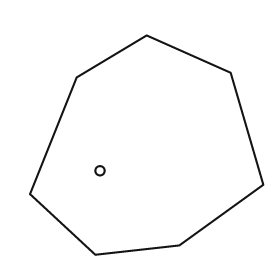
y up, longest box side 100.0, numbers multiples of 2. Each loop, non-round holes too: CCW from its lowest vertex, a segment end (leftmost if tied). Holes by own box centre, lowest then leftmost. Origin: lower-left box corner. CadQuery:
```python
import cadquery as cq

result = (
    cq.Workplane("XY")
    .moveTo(28.0, 0.0)
    .lineTo(64.0, 4.0)
    .lineTo(100.0, 30.0)
    .lineTo(86.0, 78.0)
    .lineTo(50.0, 94.0)
    .lineTo(20.0, 76.0)
    .lineTo(0.0, 26.0)
    .close()
    .moveTo(30.0, 36.0)
    .circle(2.0)
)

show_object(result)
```